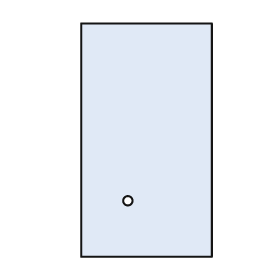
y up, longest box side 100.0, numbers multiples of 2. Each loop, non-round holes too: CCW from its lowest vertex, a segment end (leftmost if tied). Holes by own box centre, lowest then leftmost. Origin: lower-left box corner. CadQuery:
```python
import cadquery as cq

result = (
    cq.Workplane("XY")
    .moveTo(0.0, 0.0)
    .lineTo(56.0, 0.0)
    .lineTo(56.0, 100.0)
    .lineTo(0.0, 100.0)
    .close()
    .moveTo(20.0, 24.0)
    .circle(2.0)
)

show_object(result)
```